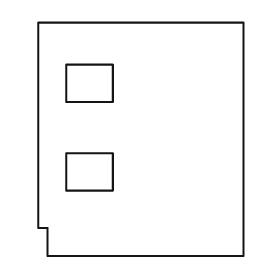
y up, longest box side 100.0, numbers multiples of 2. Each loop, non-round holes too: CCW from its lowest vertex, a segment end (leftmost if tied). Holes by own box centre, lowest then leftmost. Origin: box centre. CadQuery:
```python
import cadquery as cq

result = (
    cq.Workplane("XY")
    .moveTo(-40.0, -50.0)
    .lineTo(44.0, -50.0)
    .lineTo(44.0, 50.0)
    .lineTo(-44.0, 50.0)
    .lineTo(-44.0, -38.0)
    .lineTo(-40.0, -38.0)
    .close()
    .moveTo(-32.0, -22.0)
    .lineTo(-12.0, -22.0)
    .lineTo(-12.0, -6.0)
    .lineTo(-32.0, -6.0)
    .close()
    .moveTo(-32.0, 16.0)
    .lineTo(-12.0, 16.0)
    .lineTo(-12.0, 32.0)
    .lineTo(-32.0, 32.0)
    .close()
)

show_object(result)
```